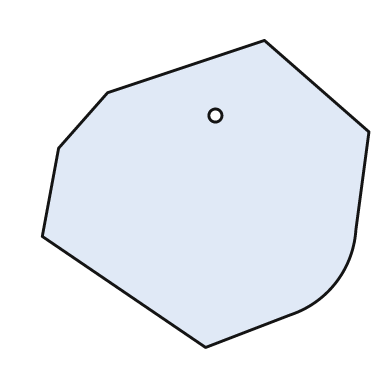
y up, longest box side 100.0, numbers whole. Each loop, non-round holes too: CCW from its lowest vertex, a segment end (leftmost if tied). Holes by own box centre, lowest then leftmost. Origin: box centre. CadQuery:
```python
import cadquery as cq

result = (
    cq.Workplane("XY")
    .moveTo(0.0, -47.0)
    .lineTo(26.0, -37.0)
    .threePointArc((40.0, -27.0), (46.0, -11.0))
    .lineTo(50.0, 19.0)
    .lineTo(18.0, 47.0)
    .lineTo(-30.0, 31.0)
    .lineTo(-45.0, 14.0)
    .lineTo(-50.0, -13.0)
    .close()
    .moveTo(3.0, 24.0)
    .circle(2.0)
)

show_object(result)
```